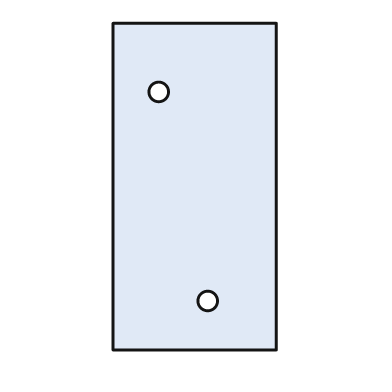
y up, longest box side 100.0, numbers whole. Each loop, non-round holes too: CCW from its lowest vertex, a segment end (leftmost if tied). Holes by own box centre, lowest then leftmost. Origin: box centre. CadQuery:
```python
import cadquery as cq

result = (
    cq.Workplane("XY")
    .moveTo(-25.0, -50.0)
    .lineTo(25.0, -50.0)
    .lineTo(25.0, 50.0)
    .lineTo(-25.0, 50.0)
    .close()
    .moveTo(4.0, -35.0)
    .circle(3.0)
    .moveTo(-11.0, 29.0)
    .circle(3.0)
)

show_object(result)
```